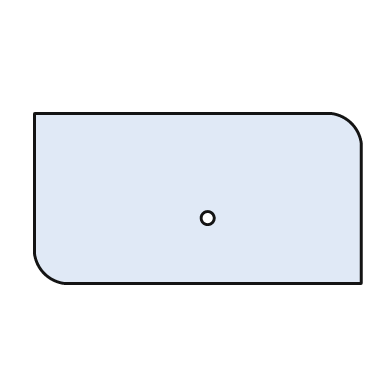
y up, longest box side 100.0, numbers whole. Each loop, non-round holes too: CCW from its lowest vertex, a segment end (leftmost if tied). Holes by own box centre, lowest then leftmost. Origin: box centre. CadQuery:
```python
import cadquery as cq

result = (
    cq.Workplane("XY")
    .moveTo(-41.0, -26.0)
    .lineTo(50.0, -26.0)
    .lineTo(50.0, 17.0)
    .threePointArc((47.0, 23.0), (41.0, 26.0))
    .lineTo(-50.0, 26.0)
    .lineTo(-50.0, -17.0)
    .threePointArc((-47.0, -23.0), (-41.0, -26.0))
    .close()
    .moveTo(3.0, -6.0)
    .circle(2.0)
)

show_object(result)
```